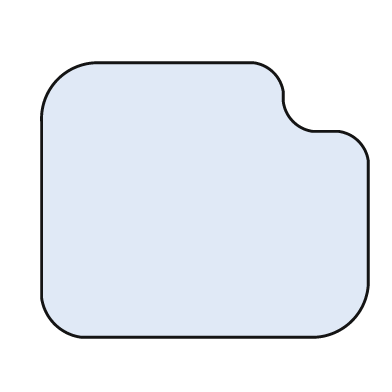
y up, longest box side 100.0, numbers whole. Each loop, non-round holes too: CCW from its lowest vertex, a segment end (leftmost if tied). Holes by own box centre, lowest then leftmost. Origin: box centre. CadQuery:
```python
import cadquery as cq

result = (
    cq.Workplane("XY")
    .moveTo(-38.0, -42.0)
    .lineTo(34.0, -42.0)
    .threePointArc((45.0, -37.0), (50.0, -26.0))
    .lineTo(50.0, 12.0)
    .threePointArc((47.0, 18.0), (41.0, 21.0))
    .lineTo(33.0, 21.0)
    .threePointArc((27.0, 24.0), (24.0, 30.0))
    .lineTo(24.0, 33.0)
    .threePointArc((21.0, 39.0), (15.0, 42.0))
    .lineTo(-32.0, 42.0)
    .threePointArc((-45.0, 37.0), (-50.0, 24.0))
    .lineTo(-50.0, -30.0)
    .threePointArc((-46.0, -38.0), (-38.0, -42.0))
    .close()
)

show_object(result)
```